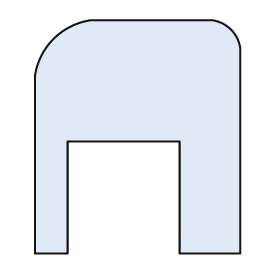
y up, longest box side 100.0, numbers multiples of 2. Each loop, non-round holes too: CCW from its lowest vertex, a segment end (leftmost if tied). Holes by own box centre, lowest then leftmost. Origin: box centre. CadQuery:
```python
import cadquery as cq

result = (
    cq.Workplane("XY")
    .moveTo(-44.0, -50.0)
    .lineTo(-30.0, -50.0)
    .lineTo(-30.0, -2.0)
    .lineTo(18.0, -2.0)
    .lineTo(18.0, -50.0)
    .lineTo(44.0, -50.0)
    .lineTo(44.0, 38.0)
    .threePointArc((40.0, 46.0), (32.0, 50.0))
    .lineTo(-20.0, 50.0)
    .threePointArc((-36.0, 42.0), (-44.0, 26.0))
    .close()
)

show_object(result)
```